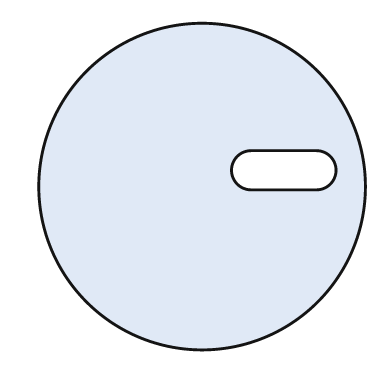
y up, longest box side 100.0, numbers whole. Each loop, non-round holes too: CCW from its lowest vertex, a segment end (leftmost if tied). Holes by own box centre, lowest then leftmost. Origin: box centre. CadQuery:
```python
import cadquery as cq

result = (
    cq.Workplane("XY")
    .moveTo(0.0, 0.0)
    .circle(50.0)
    .moveTo(15.0, -1.0)
    .lineTo(35.0, -1.0)
    .threePointArc((41.0, 5.0), (35.0, 11.0))
    .lineTo(15.0, 11.0)
    .threePointArc((9.0, 5.0), (15.0, -1.0))
    .close()
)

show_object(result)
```